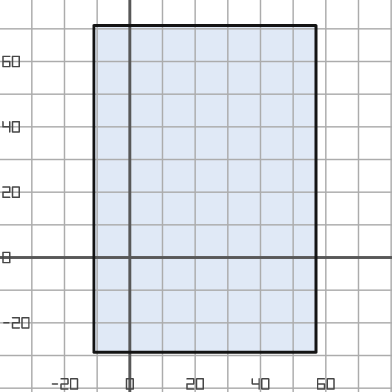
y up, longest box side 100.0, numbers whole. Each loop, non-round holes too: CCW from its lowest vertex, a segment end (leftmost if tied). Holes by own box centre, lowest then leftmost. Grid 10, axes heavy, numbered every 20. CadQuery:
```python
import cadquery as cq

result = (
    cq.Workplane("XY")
    .moveTo(-11.0, -29.0)
    .lineTo(57.0, -29.0)
    .lineTo(57.0, 71.0)
    .lineTo(-11.0, 71.0)
    .close()
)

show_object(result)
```